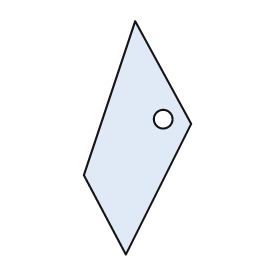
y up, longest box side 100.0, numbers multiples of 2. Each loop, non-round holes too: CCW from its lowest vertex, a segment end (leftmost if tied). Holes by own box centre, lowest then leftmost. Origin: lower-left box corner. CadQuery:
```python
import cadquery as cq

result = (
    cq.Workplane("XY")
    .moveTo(18.0, 0.0)
    .lineTo(46.0, 56.0)
    .lineTo(22.0, 100.0)
    .lineTo(0.0, 34.0)
    .close()
    .moveTo(34.0, 58.0)
    .circle(4.0)
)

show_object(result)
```